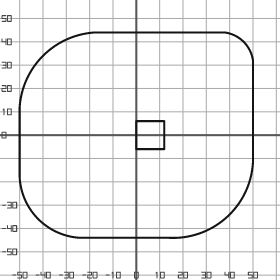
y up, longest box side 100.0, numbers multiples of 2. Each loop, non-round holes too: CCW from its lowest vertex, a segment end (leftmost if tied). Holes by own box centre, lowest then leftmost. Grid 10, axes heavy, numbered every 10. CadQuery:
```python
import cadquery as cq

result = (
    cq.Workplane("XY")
    .moveTo(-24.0, -44.0)
    .lineTo(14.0, -44.0)
    .threePointArc((40.0, -34.0), (50.0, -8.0))
    .lineTo(50.0, 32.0)
    .threePointArc((46.0, 40.0), (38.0, 44.0))
    .lineTo(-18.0, 44.0)
    .threePointArc((-40.0, 34.0), (-50.0, 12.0))
    .lineTo(-50.0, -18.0)
    .threePointArc((-42.0, -36.0), (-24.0, -44.0))
    .close()
    .moveTo(0.0, -6.0)
    .lineTo(12.0, -6.0)
    .lineTo(12.0, 6.0)
    .lineTo(0.0, 6.0)
    .close()
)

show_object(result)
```